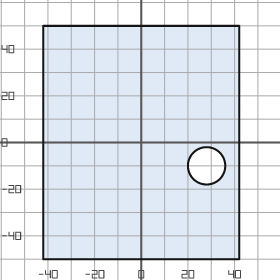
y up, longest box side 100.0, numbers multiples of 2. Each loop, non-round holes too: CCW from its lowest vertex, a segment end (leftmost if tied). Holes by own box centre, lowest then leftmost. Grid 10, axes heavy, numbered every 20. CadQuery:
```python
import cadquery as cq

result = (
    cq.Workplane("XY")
    .moveTo(-42.0, -50.0)
    .lineTo(42.0, -50.0)
    .lineTo(42.0, 50.0)
    .lineTo(-42.0, 50.0)
    .close()
    .moveTo(28.0, -10.0)
    .circle(8.0)
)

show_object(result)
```